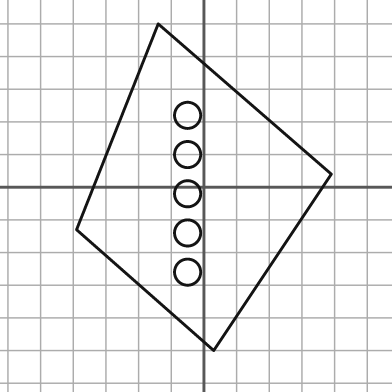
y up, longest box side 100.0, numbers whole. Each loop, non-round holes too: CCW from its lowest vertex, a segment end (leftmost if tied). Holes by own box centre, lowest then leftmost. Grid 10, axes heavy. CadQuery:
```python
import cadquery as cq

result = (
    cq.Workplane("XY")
    .moveTo(3.0, -50.0)
    .lineTo(39.0, 4.0)
    .lineTo(-14.0, 50.0)
    .lineTo(-39.0, -13.0)
    .close()
    .moveTo(-5.0, -26.0)
    .circle(4.0)
    .moveTo(-5.0, -14.0)
    .circle(4.0)
    .moveTo(-5.0, -2.0)
    .circle(4.0)
    .moveTo(-5.0, 10.0)
    .circle(4.0)
    .moveTo(-5.0, 22.0)
    .circle(4.0)
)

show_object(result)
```